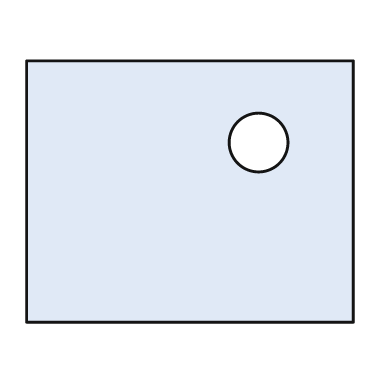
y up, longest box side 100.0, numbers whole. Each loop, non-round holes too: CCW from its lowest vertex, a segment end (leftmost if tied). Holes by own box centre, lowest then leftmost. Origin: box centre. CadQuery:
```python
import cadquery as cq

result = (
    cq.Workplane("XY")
    .moveTo(-50.0, -40.0)
    .lineTo(50.0, -40.0)
    .lineTo(50.0, 40.0)
    .lineTo(-50.0, 40.0)
    .close()
    .moveTo(21.0, 15.0)
    .circle(9.0)
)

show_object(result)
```